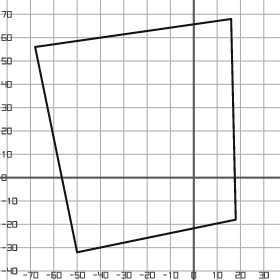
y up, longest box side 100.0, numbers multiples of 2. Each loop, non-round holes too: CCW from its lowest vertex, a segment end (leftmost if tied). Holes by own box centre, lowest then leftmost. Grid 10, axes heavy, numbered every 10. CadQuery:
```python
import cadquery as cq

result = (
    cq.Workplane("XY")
    .moveTo(-50.0, -32.0)
    .lineTo(18.0, -18.0)
    .lineTo(16.0, 68.0)
    .lineTo(-68.0, 56.0)
    .close()
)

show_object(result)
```